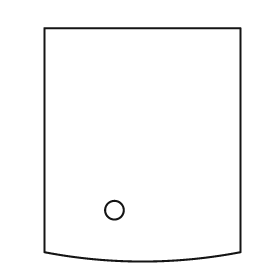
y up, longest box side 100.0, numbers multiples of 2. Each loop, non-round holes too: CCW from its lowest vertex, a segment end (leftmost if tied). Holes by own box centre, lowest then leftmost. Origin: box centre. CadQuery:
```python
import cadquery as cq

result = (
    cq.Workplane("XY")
    .moveTo(-42.0, -46.0)
    .threePointArc((0.0, -50.0), (42.0, -46.0))
    .lineTo(42.0, 50.0)
    .lineTo(-42.0, 50.0)
    .close()
    .moveTo(-12.0, -28.0)
    .circle(4.0)
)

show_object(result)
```